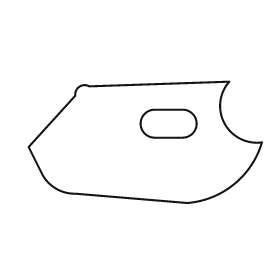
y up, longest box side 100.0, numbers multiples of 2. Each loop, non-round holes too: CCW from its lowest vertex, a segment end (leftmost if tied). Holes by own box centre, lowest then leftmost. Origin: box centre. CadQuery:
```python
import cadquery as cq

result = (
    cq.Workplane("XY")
    .moveTo(18.0, -26.0)
    .threePointArc((38.0, -18.0), (50.0, 0.0))
    .threePointArc((34.0, 8.0), (36.0, 26.0))
    .lineTo(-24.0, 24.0)
    .threePointArc((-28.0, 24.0), (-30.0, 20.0))
    .lineTo(-50.0, -2.0)
    .lineTo(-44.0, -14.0)
    .threePointArc((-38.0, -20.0), (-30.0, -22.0))
    .close()
    .moveTo(4.0, 2.0)
    .lineTo(16.0, 2.0)
    .threePointArc((22.0, 8.0), (16.0, 14.0))
    .lineTo(4.0, 14.0)
    .threePointArc((-2.0, 8.0), (4.0, 2.0))
    .close()
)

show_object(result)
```